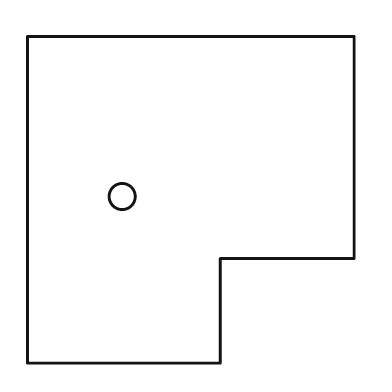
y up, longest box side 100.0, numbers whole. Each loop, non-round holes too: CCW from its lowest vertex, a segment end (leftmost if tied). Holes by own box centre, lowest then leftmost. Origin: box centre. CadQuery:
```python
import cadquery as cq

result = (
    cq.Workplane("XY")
    .moveTo(-50.0, -50.0)
    .lineTo(9.0, -50.0)
    .lineTo(9.0, -18.0)
    .lineTo(50.0, -18.0)
    .lineTo(50.0, 50.0)
    .lineTo(-50.0, 50.0)
    .close()
    .moveTo(-21.0, 1.0)
    .circle(4.0)
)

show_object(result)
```